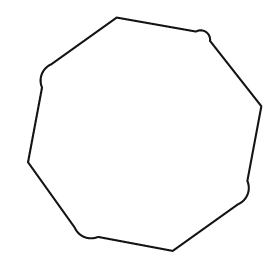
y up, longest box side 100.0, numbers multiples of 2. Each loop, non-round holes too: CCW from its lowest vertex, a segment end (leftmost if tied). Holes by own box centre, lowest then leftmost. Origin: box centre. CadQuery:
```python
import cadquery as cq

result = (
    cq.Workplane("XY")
    .moveTo(12.0, -50.0)
    .lineTo(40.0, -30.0)
    .threePointArc((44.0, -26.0), (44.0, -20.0))
    .lineTo(50.0, 12.0)
    .lineTo(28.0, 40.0)
    .threePointArc((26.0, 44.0), (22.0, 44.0))
    .lineTo(-12.0, 50.0)
    .lineTo(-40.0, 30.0)
    .threePointArc((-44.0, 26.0), (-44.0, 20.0))
    .lineTo(-50.0, -12.0)
    .lineTo(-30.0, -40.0)
    .threePointArc((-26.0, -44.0), (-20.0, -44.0))
    .close()
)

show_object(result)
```